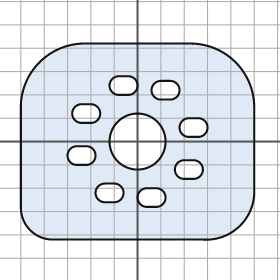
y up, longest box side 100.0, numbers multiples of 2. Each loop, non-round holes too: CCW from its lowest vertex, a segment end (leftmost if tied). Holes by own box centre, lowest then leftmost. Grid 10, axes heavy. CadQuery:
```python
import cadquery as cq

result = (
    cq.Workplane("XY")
    .moveTo(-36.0, -42.0)
    .lineTo(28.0, -42.0)
    .threePointArc((44.0, -36.0), (50.0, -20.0))
    .lineTo(50.0, 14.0)
    .threePointArc((42.0, 34.0), (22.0, 42.0))
    .lineTo(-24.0, 42.0)
    .threePointArc((-42.0, 34.0), (-50.0, 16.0))
    .lineTo(-50.0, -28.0)
    .threePointArc((-46.0, -38.0), (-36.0, -42.0))
    .close()
    .moveTo(4.0, -28.0)
    .lineTo(8.0, -28.0)
    .threePointArc((12.0, -24.0), (8.0, -20.0))
    .lineTo(4.0, -20.0)
    .threePointArc((0.0, -24.0), (4.0, -28.0))
    .close()
    .moveTo(-14.0, -26.0)
    .lineTo(-10.0, -26.0)
    .threePointArc((-6.0, -22.0), (-10.0, -18.0))
    .lineTo(-14.0, -18.0)
    .threePointArc((-18.0, -22.0), (-14.0, -26.0))
    .close()
    .moveTo(20.0, -16.0)
    .lineTo(24.0, -16.0)
    .threePointArc((28.0, -12.0), (24.0, -8.0))
    .lineTo(20.0, -8.0)
    .threePointArc((16.0, -12.0), (20.0, -16.0))
    .close()
    .moveTo(-26.0, -10.0)
    .lineTo(-22.0, -10.0)
    .threePointArc((-18.0, -6.0), (-22.0, -2.0))
    .lineTo(-26.0, -2.0)
    .threePointArc((-30.0, -6.0), (-26.0, -10.0))
    .close()
    .moveTo(0.0, 0.0)
    .circle(12.0)
    .moveTo(22.0, 2.0)
    .lineTo(26.0, 2.0)
    .threePointArc((30.0, 6.0), (26.0, 10.0))
    .lineTo(22.0, 10.0)
    .threePointArc((18.0, 6.0), (22.0, 2.0))
    .close()
    .moveTo(-24.0, 8.0)
    .lineTo(-20.0, 8.0)
    .threePointArc((-16.0, 12.0), (-20.0, 16.0))
    .lineTo(-24.0, 16.0)
    .threePointArc((-28.0, 12.0), (-24.0, 8.0))
    .close()
    .moveTo(10.0, 18.0)
    .lineTo(14.0, 18.0)
    .threePointArc((18.0, 22.0), (14.0, 26.0))
    .lineTo(10.0, 26.0)
    .threePointArc((6.0, 22.0), (10.0, 18.0))
    .close()
    .moveTo(-8.0, 20.0)
    .lineTo(-4.0, 20.0)
    .threePointArc((0.0, 24.0), (-4.0, 28.0))
    .lineTo(-8.0, 28.0)
    .threePointArc((-12.0, 24.0), (-8.0, 20.0))
    .close()
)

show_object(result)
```